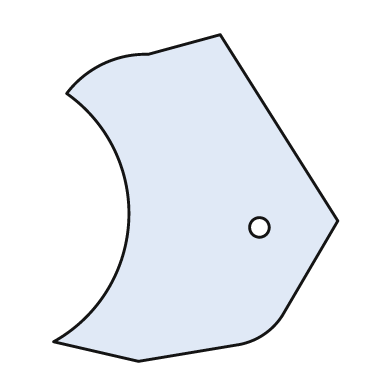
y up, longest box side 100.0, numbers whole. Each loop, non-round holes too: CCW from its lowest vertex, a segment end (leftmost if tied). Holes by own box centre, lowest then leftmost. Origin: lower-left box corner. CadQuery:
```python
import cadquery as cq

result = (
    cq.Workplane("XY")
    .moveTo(26.0, 0.0)
    .lineTo(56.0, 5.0)
    .threePointArc((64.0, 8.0), (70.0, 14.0))
    .lineTo(87.0, 43.0)
    .lineTo(51.0, 100.0)
    .lineTo(29.0, 94.0)
    .threePointArc((15.0, 91.0), (4.0, 82.0))
    .threePointArc((23.0, 43.0), (0.0, 6.0))
    .close()
    .moveTo(63.0, 41.0)
    .circle(3.0)
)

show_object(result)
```